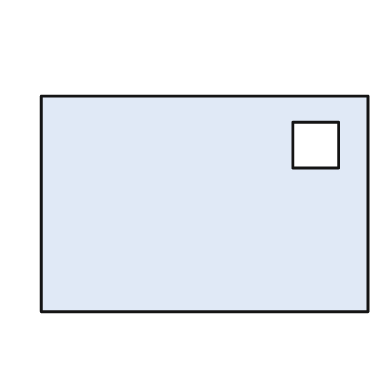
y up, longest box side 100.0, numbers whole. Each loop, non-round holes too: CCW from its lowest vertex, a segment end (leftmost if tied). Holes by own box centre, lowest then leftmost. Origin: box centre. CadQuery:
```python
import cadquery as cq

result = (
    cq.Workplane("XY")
    .moveTo(-50.0, -33.0)
    .lineTo(50.0, -33.0)
    .lineTo(50.0, 33.0)
    .lineTo(-50.0, 33.0)
    .close()
    .moveTo(27.0, 11.0)
    .lineTo(41.0, 11.0)
    .lineTo(41.0, 25.0)
    .lineTo(27.0, 25.0)
    .close()
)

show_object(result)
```